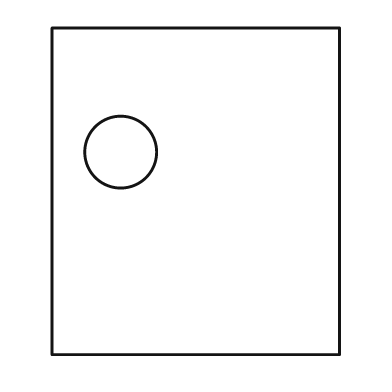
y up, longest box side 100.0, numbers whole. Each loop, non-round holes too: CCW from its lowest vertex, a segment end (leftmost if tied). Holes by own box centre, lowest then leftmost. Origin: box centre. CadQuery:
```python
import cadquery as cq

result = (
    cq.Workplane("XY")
    .moveTo(-44.0, -50.0)
    .lineTo(44.0, -50.0)
    .lineTo(44.0, 50.0)
    .lineTo(-44.0, 50.0)
    .close()
    .moveTo(-23.0, 12.0)
    .circle(11.0)
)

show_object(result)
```